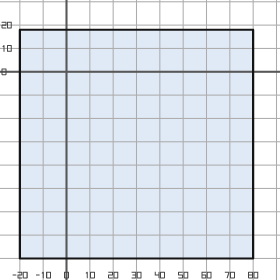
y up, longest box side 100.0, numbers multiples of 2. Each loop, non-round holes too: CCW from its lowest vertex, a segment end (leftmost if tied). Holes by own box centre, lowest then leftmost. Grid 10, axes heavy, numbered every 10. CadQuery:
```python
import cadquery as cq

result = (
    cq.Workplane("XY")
    .moveTo(-20.0, -80.0)
    .lineTo(80.0, -80.0)
    .lineTo(80.0, 18.0)
    .lineTo(-20.0, 18.0)
    .close()
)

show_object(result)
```